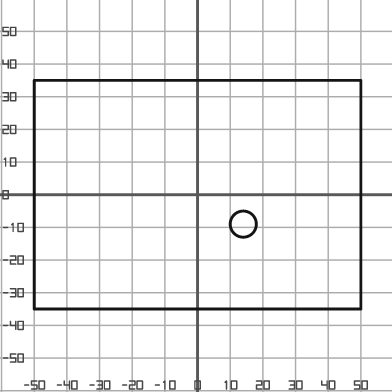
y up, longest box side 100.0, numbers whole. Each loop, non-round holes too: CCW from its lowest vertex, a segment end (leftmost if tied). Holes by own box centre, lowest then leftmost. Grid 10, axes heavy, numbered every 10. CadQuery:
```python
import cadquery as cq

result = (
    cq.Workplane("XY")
    .moveTo(-50.0, -35.0)
    .lineTo(50.0, -35.0)
    .lineTo(50.0, 35.0)
    .lineTo(-50.0, 35.0)
    .close()
    .moveTo(14.0, -9.0)
    .circle(4.0)
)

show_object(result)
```